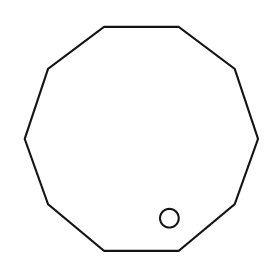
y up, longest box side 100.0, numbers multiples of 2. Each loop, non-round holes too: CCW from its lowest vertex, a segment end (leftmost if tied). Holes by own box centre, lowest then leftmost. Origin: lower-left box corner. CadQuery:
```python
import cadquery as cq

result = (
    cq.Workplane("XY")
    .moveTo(34.0, 0.0)
    .lineTo(66.0, 0.0)
    .lineTo(90.0, 20.0)
    .lineTo(100.0, 48.0)
    .lineTo(90.0, 78.0)
    .lineTo(66.0, 96.0)
    .lineTo(34.0, 96.0)
    .lineTo(10.0, 78.0)
    .lineTo(0.0, 48.0)
    .lineTo(10.0, 20.0)
    .close()
    .moveTo(62.0, 14.0)
    .circle(4.0)
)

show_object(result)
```